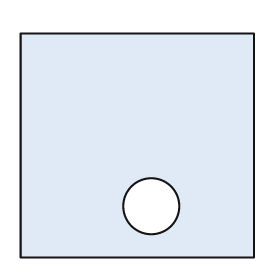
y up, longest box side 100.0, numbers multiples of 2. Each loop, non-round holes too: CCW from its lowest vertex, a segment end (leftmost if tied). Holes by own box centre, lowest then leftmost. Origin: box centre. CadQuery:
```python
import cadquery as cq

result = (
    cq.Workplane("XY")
    .moveTo(-50.0, -48.0)
    .lineTo(50.0, -48.0)
    .lineTo(50.0, 48.0)
    .lineTo(-50.0, 48.0)
    .close()
    .moveTo(6.0, -26.0)
    .circle(12.0)
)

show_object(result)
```